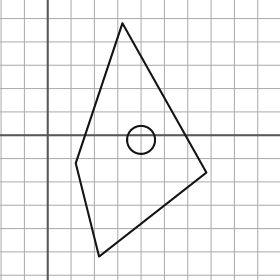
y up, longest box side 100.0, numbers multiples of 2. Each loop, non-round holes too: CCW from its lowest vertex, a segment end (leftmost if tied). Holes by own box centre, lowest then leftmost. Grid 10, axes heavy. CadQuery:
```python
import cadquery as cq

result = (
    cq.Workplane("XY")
    .moveTo(22.0, -52.0)
    .lineTo(68.0, -16.0)
    .lineTo(32.0, 48.0)
    .lineTo(12.0, -12.0)
    .close()
    .moveTo(40.0, -2.0)
    .circle(6.0)
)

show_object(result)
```